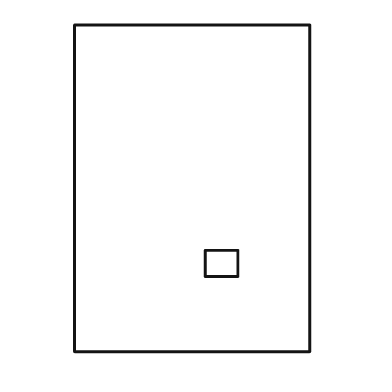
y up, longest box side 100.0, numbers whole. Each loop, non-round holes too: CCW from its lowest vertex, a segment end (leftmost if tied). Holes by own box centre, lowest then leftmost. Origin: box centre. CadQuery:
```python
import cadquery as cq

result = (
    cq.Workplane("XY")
    .moveTo(-36.0, -50.0)
    .lineTo(36.0, -50.0)
    .lineTo(36.0, 50.0)
    .lineTo(-36.0, 50.0)
    .close()
    .moveTo(4.0, -27.0)
    .lineTo(14.0, -27.0)
    .lineTo(14.0, -19.0)
    .lineTo(4.0, -19.0)
    .close()
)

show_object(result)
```